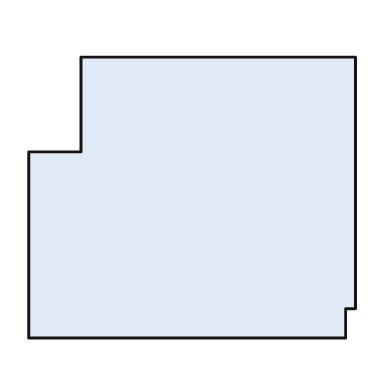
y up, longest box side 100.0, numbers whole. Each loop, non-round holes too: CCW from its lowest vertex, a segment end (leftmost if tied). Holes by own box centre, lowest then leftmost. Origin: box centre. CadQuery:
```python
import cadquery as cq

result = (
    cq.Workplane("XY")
    .moveTo(-50.0, -43.0)
    .lineTo(47.0, -43.0)
    .lineTo(47.0, -34.0)
    .lineTo(50.0, -34.0)
    .lineTo(50.0, 43.0)
    .lineTo(-34.0, 43.0)
    .lineTo(-34.0, 14.0)
    .lineTo(-50.0, 14.0)
    .close()
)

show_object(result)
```